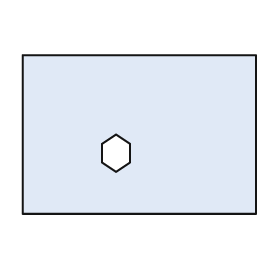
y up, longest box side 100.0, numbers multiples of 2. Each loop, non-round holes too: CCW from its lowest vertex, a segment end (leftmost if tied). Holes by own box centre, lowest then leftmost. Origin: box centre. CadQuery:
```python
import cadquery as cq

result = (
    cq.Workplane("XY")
    .moveTo(-50.0, -34.0)
    .lineTo(50.0, -34.0)
    .lineTo(50.0, 34.0)
    .lineTo(-50.0, 34.0)
    .close()
    .moveTo(-10.0, -16.0)
    .lineTo(-4.0, -12.0)
    .lineTo(-4.0, -4.0)
    .lineTo(-10.0, 0.0)
    .lineTo(-16.0, -4.0)
    .lineTo(-16.0, -12.0)
    .close()
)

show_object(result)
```